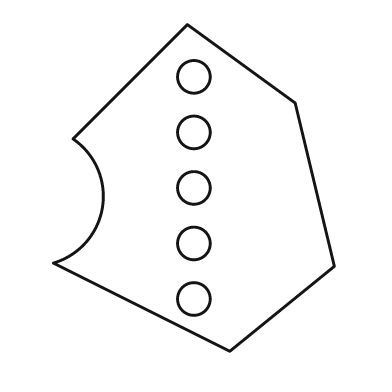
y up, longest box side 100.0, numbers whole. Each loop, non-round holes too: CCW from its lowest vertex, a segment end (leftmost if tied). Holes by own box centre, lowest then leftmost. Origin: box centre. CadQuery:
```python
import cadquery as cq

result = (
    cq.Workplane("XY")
    .moveTo(11.0, -50.0)
    .lineTo(43.0, -24.0)
    .lineTo(31.0, 26.0)
    .lineTo(-2.0, 50.0)
    .lineTo(-37.0, 15.0)
    .threePointArc((-28.0, -6.0), (-43.0, -23.0))
    .close()
    .moveTo(0.0, -34.0)
    .circle(5.0)
    .moveTo(0.0, -17.0)
    .circle(5.0)
    .moveTo(0.0, 0.0)
    .circle(5.0)
    .moveTo(0.0, 17.0)
    .circle(5.0)
    .moveTo(0.0, 34.0)
    .circle(5.0)
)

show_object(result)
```